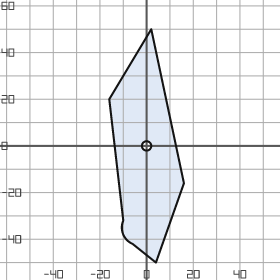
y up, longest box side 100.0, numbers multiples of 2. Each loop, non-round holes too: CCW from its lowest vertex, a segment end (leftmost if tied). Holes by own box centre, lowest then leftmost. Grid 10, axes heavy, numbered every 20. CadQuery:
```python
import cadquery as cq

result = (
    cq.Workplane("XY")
    .moveTo(4.0, -50.0)
    .lineTo(16.0, -16.0)
    .lineTo(2.0, 50.0)
    .lineTo(-16.0, 20.0)
    .lineTo(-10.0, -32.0)
    .threePointArc((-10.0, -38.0), (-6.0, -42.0))
    .close()
    .moveTo(0.0, 0.0)
    .circle(2.0)
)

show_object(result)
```